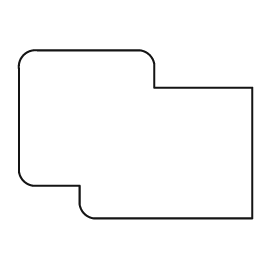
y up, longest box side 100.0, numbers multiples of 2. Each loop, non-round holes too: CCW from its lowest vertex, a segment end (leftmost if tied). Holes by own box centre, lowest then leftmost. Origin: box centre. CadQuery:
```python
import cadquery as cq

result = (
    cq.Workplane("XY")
    .moveTo(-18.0, -36.0)
    .lineTo(50.0, -36.0)
    .lineTo(50.0, 20.0)
    .lineTo(8.0, 20.0)
    .lineTo(8.0, 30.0)
    .threePointArc((6.0, 34.0), (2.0, 36.0))
    .lineTo(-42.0, 36.0)
    .threePointArc((-48.0, 34.0), (-50.0, 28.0))
    .lineTo(-50.0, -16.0)
    .threePointArc((-48.0, -20.0), (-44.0, -22.0))
    .lineTo(-24.0, -22.0)
    .lineTo(-24.0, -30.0)
    .threePointArc((-22.0, -34.0), (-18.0, -36.0))
    .close()
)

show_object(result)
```